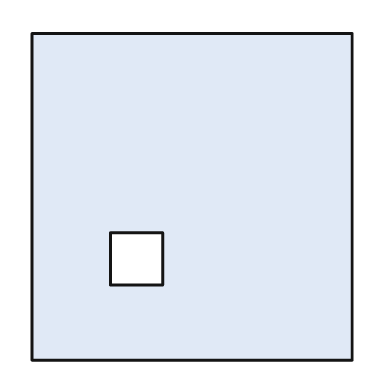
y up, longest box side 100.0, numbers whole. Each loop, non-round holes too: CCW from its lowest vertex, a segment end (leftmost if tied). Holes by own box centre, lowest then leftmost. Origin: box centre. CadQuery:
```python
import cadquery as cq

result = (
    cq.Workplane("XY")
    .moveTo(-49.0, -50.0)
    .lineTo(49.0, -50.0)
    .lineTo(49.0, 50.0)
    .lineTo(-49.0, 50.0)
    .close()
    .moveTo(-25.0, -27.0)
    .lineTo(-9.0, -27.0)
    .lineTo(-9.0, -11.0)
    .lineTo(-25.0, -11.0)
    .close()
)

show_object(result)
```